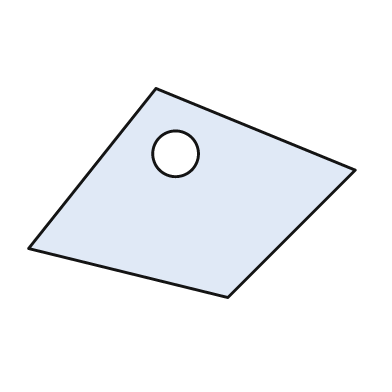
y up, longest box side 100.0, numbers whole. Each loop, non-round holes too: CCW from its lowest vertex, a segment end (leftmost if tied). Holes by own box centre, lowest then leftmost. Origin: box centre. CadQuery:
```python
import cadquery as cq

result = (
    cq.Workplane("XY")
    .moveTo(11.0, -32.0)
    .lineTo(50.0, 7.0)
    .lineTo(-11.0, 32.0)
    .lineTo(-50.0, -17.0)
    .close()
    .moveTo(-5.0, 12.0)
    .circle(7.0)
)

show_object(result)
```